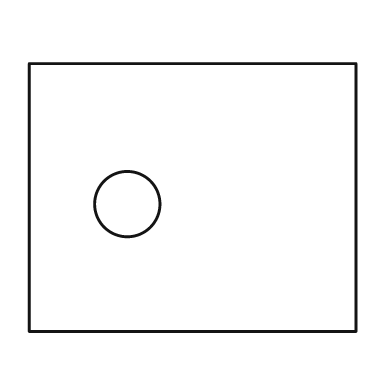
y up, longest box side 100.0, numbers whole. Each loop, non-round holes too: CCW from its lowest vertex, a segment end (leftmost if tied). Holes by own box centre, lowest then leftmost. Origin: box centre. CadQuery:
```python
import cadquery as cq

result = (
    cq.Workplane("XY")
    .moveTo(-50.0, -41.0)
    .lineTo(50.0, -41.0)
    .lineTo(50.0, 41.0)
    .lineTo(-50.0, 41.0)
    .close()
    .moveTo(-20.0, -2.0)
    .circle(10.0)
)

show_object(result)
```